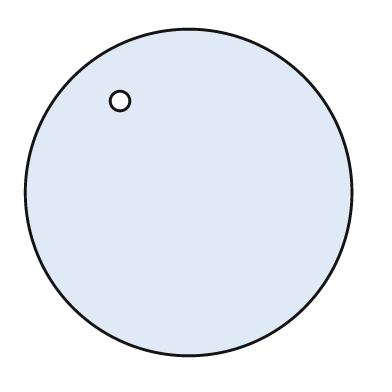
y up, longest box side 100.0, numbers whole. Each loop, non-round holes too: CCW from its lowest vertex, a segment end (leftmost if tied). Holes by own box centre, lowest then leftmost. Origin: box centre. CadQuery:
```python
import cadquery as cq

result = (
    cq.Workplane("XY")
    .moveTo(0.0, 0.0)
    .circle(50.0)
    .moveTo(-21.0, 28.0)
    .circle(3.0)
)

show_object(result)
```